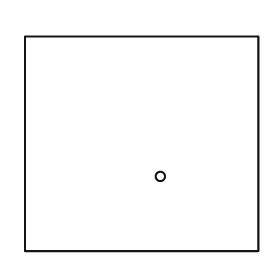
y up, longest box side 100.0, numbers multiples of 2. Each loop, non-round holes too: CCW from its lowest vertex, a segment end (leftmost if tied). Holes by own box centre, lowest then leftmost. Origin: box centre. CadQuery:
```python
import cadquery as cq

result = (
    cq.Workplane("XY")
    .moveTo(-50.0, -46.0)
    .lineTo(50.0, -46.0)
    .lineTo(50.0, 46.0)
    .lineTo(-50.0, 46.0)
    .close()
    .moveTo(8.0, -14.0)
    .circle(2.0)
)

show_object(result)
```